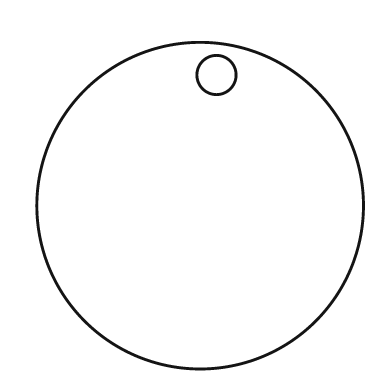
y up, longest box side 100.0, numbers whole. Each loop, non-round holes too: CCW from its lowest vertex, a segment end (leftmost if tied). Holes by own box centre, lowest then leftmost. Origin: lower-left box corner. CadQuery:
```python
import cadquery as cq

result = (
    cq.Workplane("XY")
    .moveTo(50.0, 50.0)
    .circle(50.0)
    .moveTo(55.0, 90.0)
    .circle(6.0)
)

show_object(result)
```